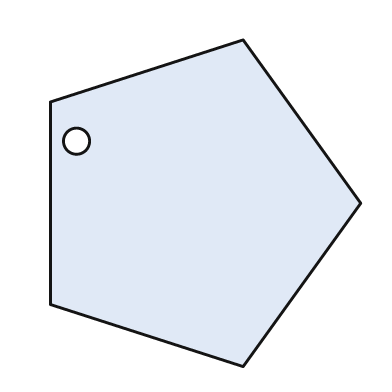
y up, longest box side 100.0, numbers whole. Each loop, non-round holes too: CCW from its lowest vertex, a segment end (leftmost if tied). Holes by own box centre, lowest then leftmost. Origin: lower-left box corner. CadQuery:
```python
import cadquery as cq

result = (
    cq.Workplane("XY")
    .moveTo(59.0, 0.0)
    .lineTo(95.0, 50.0)
    .lineTo(59.0, 100.0)
    .lineTo(0.0, 81.0)
    .lineTo(0.0, 19.0)
    .close()
    .moveTo(8.0, 69.0)
    .circle(4.0)
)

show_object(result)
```